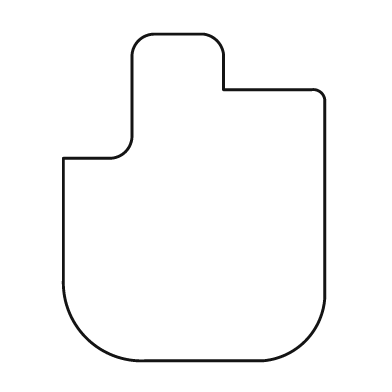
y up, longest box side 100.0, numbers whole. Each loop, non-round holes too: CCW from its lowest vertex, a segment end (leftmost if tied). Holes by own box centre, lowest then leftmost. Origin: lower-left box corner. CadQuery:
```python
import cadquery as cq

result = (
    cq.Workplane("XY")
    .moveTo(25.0, 0.0)
    .lineTo(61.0, 0.0)
    .threePointArc((74.0, 6.0), (80.0, 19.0))
    .lineTo(80.0, 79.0)
    .threePointArc((79.0, 82.0), (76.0, 83.0))
    .lineTo(49.0, 83.0)
    .lineTo(49.0, 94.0)
    .threePointArc((47.0, 98.0), (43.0, 100.0))
    .lineTo(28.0, 100.0)
    .threePointArc((23.0, 98.0), (21.0, 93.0))
    .lineTo(21.0, 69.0)
    .threePointArc((19.0, 64.0), (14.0, 62.0))
    .lineTo(0.0, 62.0)
    .lineTo(0.0, 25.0)
    .threePointArc((7.0, 7.0), (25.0, 0.0))
    .close()
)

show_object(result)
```